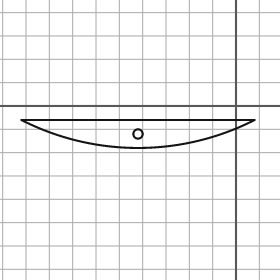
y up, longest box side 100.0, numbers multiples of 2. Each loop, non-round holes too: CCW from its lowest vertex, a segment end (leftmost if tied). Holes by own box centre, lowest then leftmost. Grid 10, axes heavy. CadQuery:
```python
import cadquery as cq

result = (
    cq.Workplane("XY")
    .moveTo(-92.0, -6.0)
    .threePointArc((-42.0, -18.0), (8.0, -6.0))
    .close()
    .moveTo(-42.0, -12.0)
    .circle(2.0)
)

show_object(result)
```